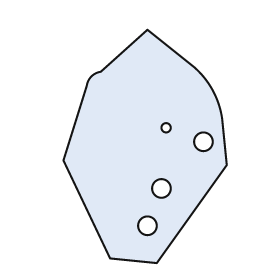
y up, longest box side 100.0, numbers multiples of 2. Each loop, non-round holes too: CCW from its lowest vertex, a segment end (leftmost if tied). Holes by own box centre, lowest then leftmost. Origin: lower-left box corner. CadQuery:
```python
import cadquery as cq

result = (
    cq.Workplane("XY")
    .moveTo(40.0, 0.0)
    .lineTo(70.0, 42.0)
    .lineTo(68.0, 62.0)
    .threePointArc((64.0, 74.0), (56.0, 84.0))
    .lineTo(36.0, 100.0)
    .lineTo(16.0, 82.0)
    .threePointArc((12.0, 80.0), (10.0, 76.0))
    .lineTo(0.0, 44.0)
    .lineTo(20.0, 2.0)
    .close()
    .moveTo(36.0, 16.0)
    .circle(4.0)
    .moveTo(42.0, 32.0)
    .circle(4.0)
    .moveTo(60.0, 52.0)
    .circle(4.0)
    .moveTo(44.0, 58.0)
    .circle(2.0)
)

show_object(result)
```